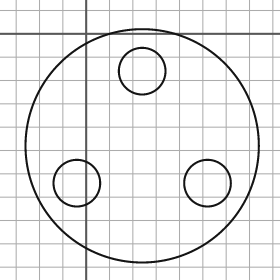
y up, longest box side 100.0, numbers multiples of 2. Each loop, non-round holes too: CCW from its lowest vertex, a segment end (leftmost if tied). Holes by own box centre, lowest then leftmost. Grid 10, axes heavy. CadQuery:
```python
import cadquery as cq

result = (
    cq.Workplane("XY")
    .moveTo(24.0, -48.0)
    .circle(50.0)
    .moveTo(-4.0, -64.0)
    .circle(10.0)
    .moveTo(52.0, -64.0)
    .circle(10.0)
    .moveTo(24.0, -16.0)
    .circle(10.0)
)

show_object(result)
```